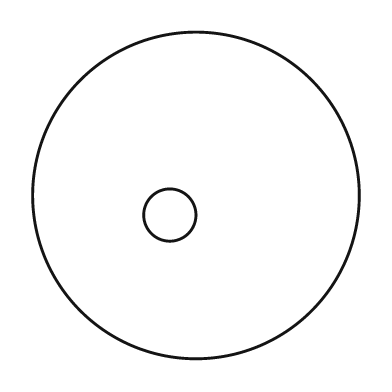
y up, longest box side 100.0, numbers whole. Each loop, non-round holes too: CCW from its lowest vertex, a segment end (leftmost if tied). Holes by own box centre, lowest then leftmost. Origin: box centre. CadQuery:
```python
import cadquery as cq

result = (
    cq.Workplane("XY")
    .moveTo(0.0, 0.0)
    .circle(50.0)
    .moveTo(-8.0, -6.0)
    .circle(8.0)
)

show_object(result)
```